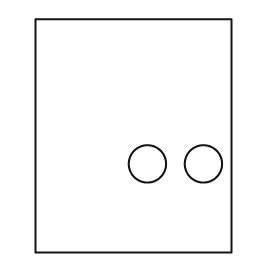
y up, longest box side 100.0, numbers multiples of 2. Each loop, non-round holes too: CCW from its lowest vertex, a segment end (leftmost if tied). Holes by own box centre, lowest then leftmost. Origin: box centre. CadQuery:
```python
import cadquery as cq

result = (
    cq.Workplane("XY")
    .moveTo(-42.0, -50.0)
    .lineTo(42.0, -50.0)
    .lineTo(42.0, 50.0)
    .lineTo(-42.0, 50.0)
    .close()
    .moveTo(6.0, -12.0)
    .circle(8.0)
    .moveTo(30.0, -12.0)
    .circle(8.0)
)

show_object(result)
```